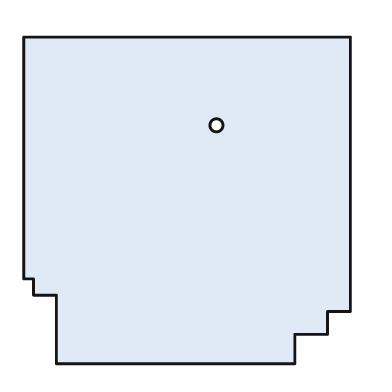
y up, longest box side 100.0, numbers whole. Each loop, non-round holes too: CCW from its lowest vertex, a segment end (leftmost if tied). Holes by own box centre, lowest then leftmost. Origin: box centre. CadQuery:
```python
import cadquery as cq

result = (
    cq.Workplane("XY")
    .moveTo(-40.0, -50.0)
    .lineTo(33.0, -50.0)
    .lineTo(33.0, -41.0)
    .lineTo(43.0, -41.0)
    .lineTo(43.0, -34.0)
    .lineTo(50.0, -34.0)
    .lineTo(50.0, 50.0)
    .lineTo(-50.0, 50.0)
    .lineTo(-50.0, -24.0)
    .lineTo(-47.0, -24.0)
    .lineTo(-47.0, -29.0)
    .lineTo(-40.0, -29.0)
    .close()
    .moveTo(9.0, 23.0)
    .circle(2.0)
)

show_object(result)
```